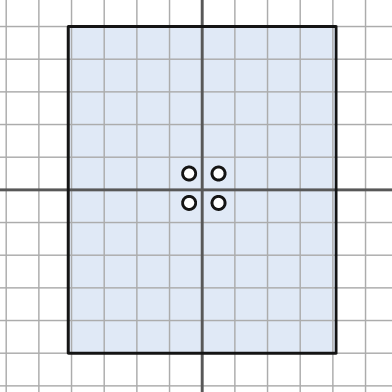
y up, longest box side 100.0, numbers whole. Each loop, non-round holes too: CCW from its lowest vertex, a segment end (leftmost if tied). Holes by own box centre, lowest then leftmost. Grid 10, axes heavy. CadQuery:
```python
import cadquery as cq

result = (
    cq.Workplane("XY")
    .moveTo(-41.0, -50.0)
    .lineTo(41.0, -50.0)
    .lineTo(41.0, 50.0)
    .lineTo(-41.0, 50.0)
    .close()
    .moveTo(-4.0, -4.0)
    .circle(2.0)
    .moveTo(5.0, -4.0)
    .circle(2.0)
    .moveTo(-4.0, 5.0)
    .circle(2.0)
    .moveTo(5.0, 5.0)
    .circle(2.0)
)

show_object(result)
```